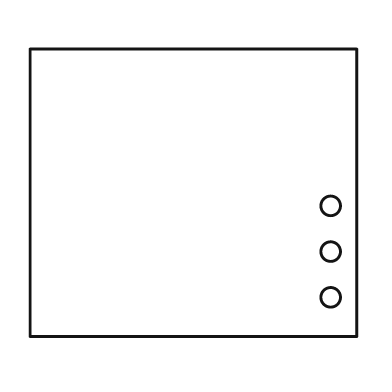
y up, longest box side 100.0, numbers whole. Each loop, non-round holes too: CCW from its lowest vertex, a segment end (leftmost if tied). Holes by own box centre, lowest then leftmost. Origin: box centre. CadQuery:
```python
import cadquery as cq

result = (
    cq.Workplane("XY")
    .moveTo(-50.0, -44.0)
    .lineTo(50.0, -44.0)
    .lineTo(50.0, 44.0)
    .lineTo(-50.0, 44.0)
    .close()
    .moveTo(42.0, -32.0)
    .circle(3.0)
    .moveTo(42.0, -18.0)
    .circle(3.0)
    .moveTo(42.0, -4.0)
    .circle(3.0)
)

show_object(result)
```